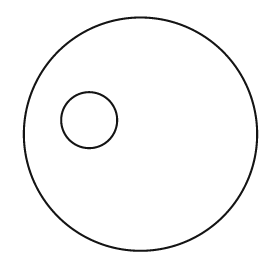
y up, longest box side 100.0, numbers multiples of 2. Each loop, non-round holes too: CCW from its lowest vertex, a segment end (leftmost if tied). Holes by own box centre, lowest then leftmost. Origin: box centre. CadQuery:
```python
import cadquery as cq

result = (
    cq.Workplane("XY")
    .moveTo(0.0, 0.0)
    .circle(50.0)
    .moveTo(-22.0, 6.0)
    .circle(12.0)
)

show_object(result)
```